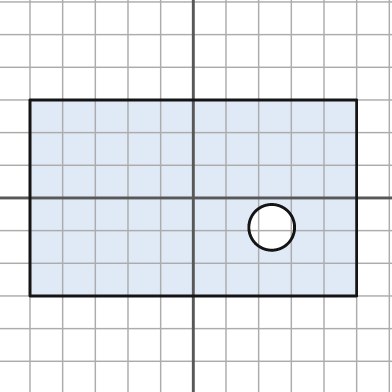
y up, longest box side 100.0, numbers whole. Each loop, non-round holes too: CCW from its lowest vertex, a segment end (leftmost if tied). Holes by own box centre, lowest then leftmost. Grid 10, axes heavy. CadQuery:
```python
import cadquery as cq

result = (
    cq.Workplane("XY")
    .moveTo(-50.0, -30.0)
    .lineTo(50.0, -30.0)
    .lineTo(50.0, 30.0)
    .lineTo(-50.0, 30.0)
    .close()
    .moveTo(24.0, -9.0)
    .circle(7.0)
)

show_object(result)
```